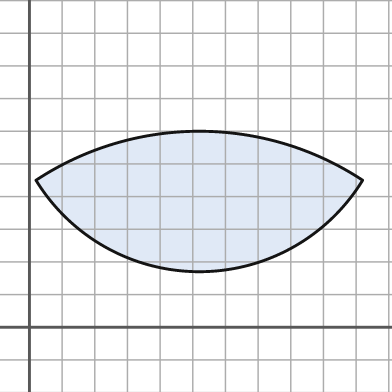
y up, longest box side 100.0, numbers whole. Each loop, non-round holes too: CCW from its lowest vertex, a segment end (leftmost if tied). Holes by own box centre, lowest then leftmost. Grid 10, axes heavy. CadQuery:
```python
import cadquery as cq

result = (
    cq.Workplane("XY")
    .moveTo(2.0, 45.0)
    .threePointArc((52.0, 17.0), (102.0, 45.0))
    .threePointArc((52.0, 60.0), (2.0, 45.0))
    .close()
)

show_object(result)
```